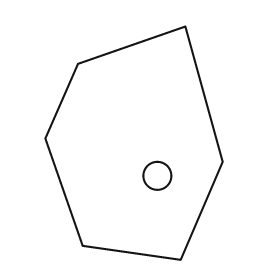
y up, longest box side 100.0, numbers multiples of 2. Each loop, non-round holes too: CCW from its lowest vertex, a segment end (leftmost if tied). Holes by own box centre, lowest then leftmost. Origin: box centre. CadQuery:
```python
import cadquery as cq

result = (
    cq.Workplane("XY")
    .moveTo(20.0, -50.0)
    .lineTo(38.0, -8.0)
    .lineTo(22.0, 50.0)
    .lineTo(-24.0, 34.0)
    .lineTo(-38.0, 2.0)
    .lineTo(-22.0, -44.0)
    .close()
    .moveTo(10.0, -14.0)
    .circle(6.0)
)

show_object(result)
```